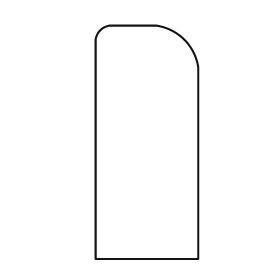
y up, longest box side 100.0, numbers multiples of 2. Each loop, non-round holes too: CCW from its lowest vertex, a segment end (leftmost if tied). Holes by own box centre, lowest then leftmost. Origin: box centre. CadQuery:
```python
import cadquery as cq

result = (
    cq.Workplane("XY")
    .moveTo(-22.0, -50.0)
    .lineTo(22.0, -50.0)
    .lineTo(22.0, 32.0)
    .threePointArc((16.0, 44.0), (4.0, 50.0))
    .lineTo(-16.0, 50.0)
    .threePointArc((-20.0, 48.0), (-22.0, 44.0))
    .close()
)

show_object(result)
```